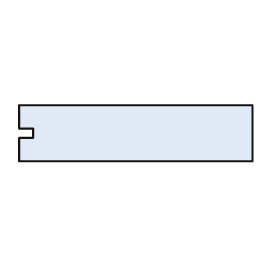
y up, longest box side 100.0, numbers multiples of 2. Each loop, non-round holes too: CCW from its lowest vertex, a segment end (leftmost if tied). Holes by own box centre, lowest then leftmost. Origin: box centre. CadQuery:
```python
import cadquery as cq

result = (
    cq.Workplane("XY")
    .moveTo(-50.0, -12.0)
    .lineTo(50.0, -12.0)
    .lineTo(50.0, 12.0)
    .lineTo(-50.0, 12.0)
    .lineTo(-50.0, 2.0)
    .lineTo(-44.0, 2.0)
    .lineTo(-44.0, -2.0)
    .lineTo(-50.0, -2.0)
    .close()
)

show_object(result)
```